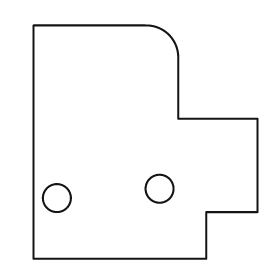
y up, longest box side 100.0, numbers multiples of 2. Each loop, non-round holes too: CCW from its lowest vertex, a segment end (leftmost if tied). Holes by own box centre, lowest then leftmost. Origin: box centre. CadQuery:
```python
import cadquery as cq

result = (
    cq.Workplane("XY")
    .moveTo(-48.0, -50.0)
    .lineTo(26.0, -50.0)
    .lineTo(26.0, -30.0)
    .lineTo(48.0, -30.0)
    .lineTo(48.0, 10.0)
    .lineTo(14.0, 10.0)
    .lineTo(14.0, 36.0)
    .threePointArc((10.0, 46.0), (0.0, 50.0))
    .lineTo(-48.0, 50.0)
    .close()
    .moveTo(-38.0, -24.0)
    .circle(6.0)
    .moveTo(6.0, -20.0)
    .circle(6.0)
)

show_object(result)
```